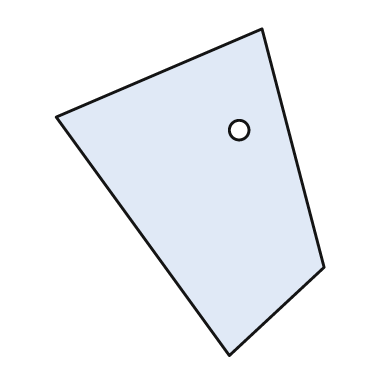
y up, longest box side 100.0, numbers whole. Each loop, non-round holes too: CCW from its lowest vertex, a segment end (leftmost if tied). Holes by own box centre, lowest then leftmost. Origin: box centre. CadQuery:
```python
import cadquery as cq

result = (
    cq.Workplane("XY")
    .moveTo(12.0, -50.0)
    .lineTo(41.0, -23.0)
    .lineTo(22.0, 50.0)
    .lineTo(-41.0, 23.0)
    .close()
    .moveTo(15.0, 19.0)
    .circle(3.0)
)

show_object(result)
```